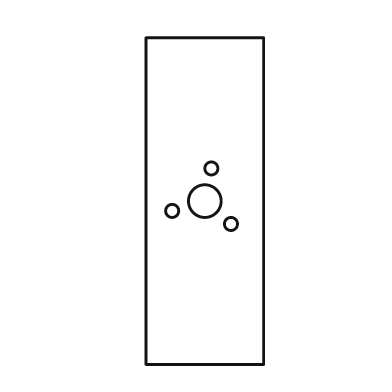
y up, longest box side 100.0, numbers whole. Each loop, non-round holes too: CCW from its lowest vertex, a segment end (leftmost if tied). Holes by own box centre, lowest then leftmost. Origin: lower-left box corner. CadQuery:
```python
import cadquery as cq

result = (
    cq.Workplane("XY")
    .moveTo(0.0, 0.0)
    .lineTo(36.0, 0.0)
    .lineTo(36.0, 100.0)
    .lineTo(0.0, 100.0)
    .close()
    .moveTo(26.0, 43.0)
    .circle(2.0)
    .moveTo(8.0, 47.0)
    .circle(2.0)
    .moveTo(18.0, 50.0)
    .circle(5.0)
    .moveTo(20.0, 60.0)
    .circle(2.0)
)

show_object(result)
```